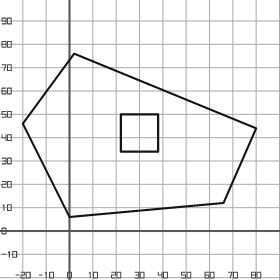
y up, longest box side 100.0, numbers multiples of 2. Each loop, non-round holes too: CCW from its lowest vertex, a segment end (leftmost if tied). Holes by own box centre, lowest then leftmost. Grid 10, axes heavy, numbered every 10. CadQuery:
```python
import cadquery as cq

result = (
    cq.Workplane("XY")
    .moveTo(0.0, 6.0)
    .lineTo(66.0, 12.0)
    .lineTo(80.0, 44.0)
    .lineTo(2.0, 76.0)
    .lineTo(-20.0, 46.0)
    .close()
    .moveTo(22.0, 34.0)
    .lineTo(38.0, 34.0)
    .lineTo(38.0, 50.0)
    .lineTo(22.0, 50.0)
    .close()
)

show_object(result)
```